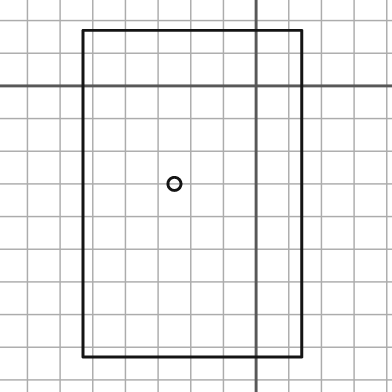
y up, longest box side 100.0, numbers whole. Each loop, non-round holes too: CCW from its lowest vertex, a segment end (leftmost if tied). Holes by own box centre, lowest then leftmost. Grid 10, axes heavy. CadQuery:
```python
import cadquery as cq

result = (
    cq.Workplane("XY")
    .moveTo(-53.0, -83.0)
    .lineTo(14.0, -83.0)
    .lineTo(14.0, 17.0)
    .lineTo(-53.0, 17.0)
    .close()
    .moveTo(-25.0, -30.0)
    .circle(2.0)
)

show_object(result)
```